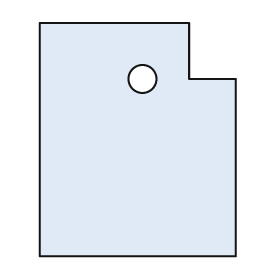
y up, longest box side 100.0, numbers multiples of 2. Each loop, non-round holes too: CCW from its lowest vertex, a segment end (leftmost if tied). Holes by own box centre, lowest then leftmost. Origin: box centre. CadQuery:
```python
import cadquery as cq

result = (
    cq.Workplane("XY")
    .moveTo(-42.0, -50.0)
    .lineTo(42.0, -50.0)
    .lineTo(42.0, 26.0)
    .lineTo(22.0, 26.0)
    .lineTo(22.0, 50.0)
    .lineTo(-42.0, 50.0)
    .close()
    .moveTo(2.0, 26.0)
    .circle(6.0)
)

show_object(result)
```